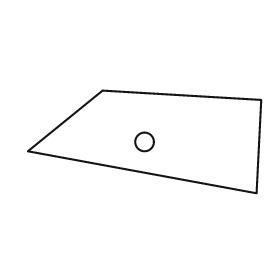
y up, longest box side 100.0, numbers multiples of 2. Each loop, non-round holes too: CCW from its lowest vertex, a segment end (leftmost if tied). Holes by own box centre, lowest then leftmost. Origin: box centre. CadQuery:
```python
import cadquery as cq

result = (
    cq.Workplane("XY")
    .moveTo(48.0, -22.0)
    .lineTo(50.0, 18.0)
    .lineTo(-18.0, 22.0)
    .lineTo(-50.0, -4.0)
    .close()
    .moveTo(0.0, 0.0)
    .circle(4.0)
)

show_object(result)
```